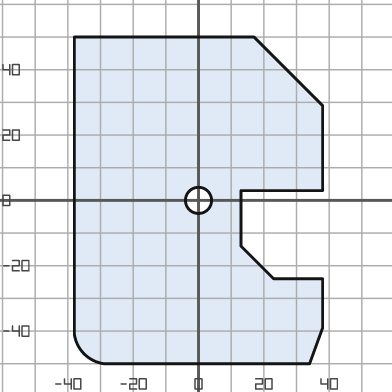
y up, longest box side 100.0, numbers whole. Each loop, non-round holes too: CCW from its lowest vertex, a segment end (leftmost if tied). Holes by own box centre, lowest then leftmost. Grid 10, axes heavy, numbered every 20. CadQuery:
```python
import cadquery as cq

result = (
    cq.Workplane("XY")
    .moveTo(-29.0, -50.0)
    .lineTo(34.0, -50.0)
    .lineTo(38.0, -39.0)
    .lineTo(38.0, -24.0)
    .lineTo(23.0, -24.0)
    .lineTo(13.0, -14.0)
    .lineTo(13.0, 3.0)
    .lineTo(38.0, 3.0)
    .lineTo(38.0, 29.0)
    .lineTo(17.0, 50.0)
    .lineTo(-38.0, 50.0)
    .lineTo(-38.0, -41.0)
    .threePointArc((-35.0, -47.0), (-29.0, -50.0))
    .close()
    .moveTo(0.0, 0.0)
    .circle(4.0)
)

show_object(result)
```